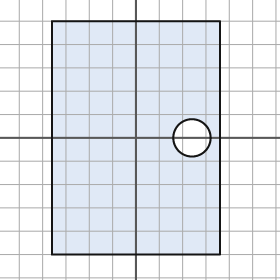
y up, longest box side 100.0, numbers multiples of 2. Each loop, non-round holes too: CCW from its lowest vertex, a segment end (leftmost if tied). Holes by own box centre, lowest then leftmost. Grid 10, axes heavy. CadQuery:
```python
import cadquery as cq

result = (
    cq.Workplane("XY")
    .moveTo(-36.0, -50.0)
    .lineTo(36.0, -50.0)
    .lineTo(36.0, 50.0)
    .lineTo(-36.0, 50.0)
    .close()
    .moveTo(24.0, 0.0)
    .circle(8.0)
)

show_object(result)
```